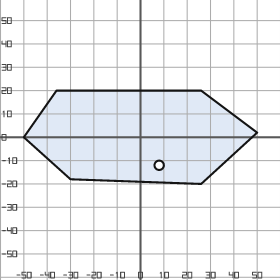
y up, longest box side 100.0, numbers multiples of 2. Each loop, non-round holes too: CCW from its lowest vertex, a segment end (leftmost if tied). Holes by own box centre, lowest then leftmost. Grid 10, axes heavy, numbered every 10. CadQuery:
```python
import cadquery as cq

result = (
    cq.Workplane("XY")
    .moveTo(26.0, -20.0)
    .lineTo(50.0, 2.0)
    .lineTo(26.0, 20.0)
    .lineTo(-36.0, 20.0)
    .lineTo(-50.0, 0.0)
    .lineTo(-30.0, -18.0)
    .close()
    .moveTo(8.0, -12.0)
    .circle(2.0)
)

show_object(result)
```